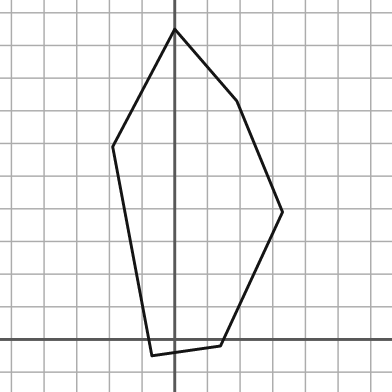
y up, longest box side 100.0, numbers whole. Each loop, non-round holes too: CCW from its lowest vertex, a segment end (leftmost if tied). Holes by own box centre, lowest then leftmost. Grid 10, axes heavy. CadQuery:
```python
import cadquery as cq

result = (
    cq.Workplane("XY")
    .moveTo(-7.0, -5.0)
    .lineTo(14.0, -2.0)
    .lineTo(33.0, 39.0)
    .lineTo(19.0, 73.0)
    .lineTo(0.0, 95.0)
    .lineTo(-19.0, 59.0)
    .close()
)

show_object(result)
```